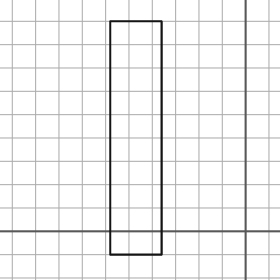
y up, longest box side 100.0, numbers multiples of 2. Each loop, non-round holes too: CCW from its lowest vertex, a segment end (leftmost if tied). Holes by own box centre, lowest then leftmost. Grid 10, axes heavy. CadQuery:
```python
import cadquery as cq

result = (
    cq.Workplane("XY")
    .moveTo(-58.0, -10.0)
    .lineTo(-36.0, -10.0)
    .lineTo(-36.0, 90.0)
    .lineTo(-58.0, 90.0)
    .close()
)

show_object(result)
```